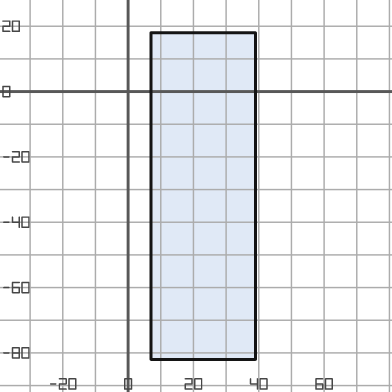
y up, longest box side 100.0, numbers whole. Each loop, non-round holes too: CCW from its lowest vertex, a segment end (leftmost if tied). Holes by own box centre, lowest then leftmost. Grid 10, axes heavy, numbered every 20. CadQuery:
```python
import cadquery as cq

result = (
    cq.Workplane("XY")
    .moveTo(7.0, -82.0)
    .lineTo(39.0, -82.0)
    .lineTo(39.0, 18.0)
    .lineTo(7.0, 18.0)
    .close()
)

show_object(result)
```